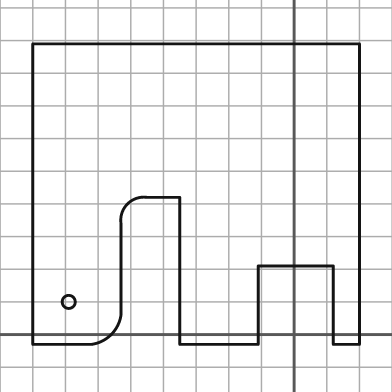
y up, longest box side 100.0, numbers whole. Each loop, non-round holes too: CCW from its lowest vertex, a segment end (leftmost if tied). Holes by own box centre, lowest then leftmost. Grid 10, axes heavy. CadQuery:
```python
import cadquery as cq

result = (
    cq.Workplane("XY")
    .moveTo(-80.0, -3.0)
    .lineTo(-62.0, -3.0)
    .threePointArc((-56.0, 0.0), (-53.0, 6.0))
    .lineTo(-53.0, 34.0)
    .threePointArc((-51.0, 40.0), (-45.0, 42.0))
    .lineTo(-35.0, 42.0)
    .lineTo(-35.0, -3.0)
    .lineTo(-11.0, -3.0)
    .lineTo(-11.0, 21.0)
    .lineTo(12.0, 21.0)
    .lineTo(12.0, -3.0)
    .lineTo(20.0, -3.0)
    .lineTo(20.0, 89.0)
    .lineTo(-80.0, 89.0)
    .close()
    .moveTo(-69.0, 10.0)
    .circle(2.0)
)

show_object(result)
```